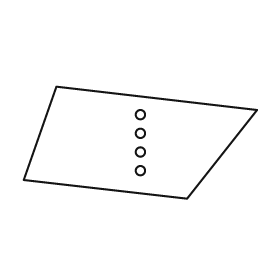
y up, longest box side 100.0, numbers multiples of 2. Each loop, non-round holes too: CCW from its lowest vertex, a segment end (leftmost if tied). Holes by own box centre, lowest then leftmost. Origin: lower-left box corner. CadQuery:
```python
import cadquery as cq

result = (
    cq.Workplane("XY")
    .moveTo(70.0, 0.0)
    .lineTo(100.0, 38.0)
    .lineTo(14.0, 48.0)
    .lineTo(0.0, 8.0)
    .close()
    .moveTo(50.0, 12.0)
    .circle(2.0)
    .moveTo(50.0, 20.0)
    .circle(2.0)
    .moveTo(50.0, 28.0)
    .circle(2.0)
    .moveTo(50.0, 36.0)
    .circle(2.0)
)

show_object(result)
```